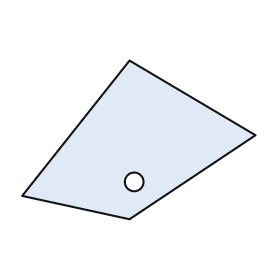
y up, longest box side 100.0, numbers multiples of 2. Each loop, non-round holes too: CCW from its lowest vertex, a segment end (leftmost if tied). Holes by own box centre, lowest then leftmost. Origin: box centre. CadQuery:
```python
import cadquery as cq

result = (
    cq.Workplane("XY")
    .moveTo(-4.0, -34.0)
    .lineTo(50.0, 2.0)
    .lineTo(-4.0, 34.0)
    .lineTo(-50.0, -24.0)
    .close()
    .moveTo(-2.0, -18.0)
    .circle(4.0)
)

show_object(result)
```